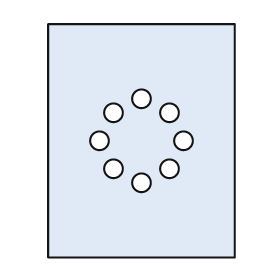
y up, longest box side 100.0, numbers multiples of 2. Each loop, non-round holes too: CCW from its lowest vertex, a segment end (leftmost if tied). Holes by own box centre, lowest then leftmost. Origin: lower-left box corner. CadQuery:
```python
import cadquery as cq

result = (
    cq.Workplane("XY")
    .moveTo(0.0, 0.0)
    .lineTo(80.0, 0.0)
    .lineTo(80.0, 100.0)
    .lineTo(0.0, 100.0)
    .close()
    .moveTo(40.0, 32.0)
    .circle(4.0)
    .moveTo(28.0, 38.0)
    .circle(4.0)
    .moveTo(52.0, 38.0)
    .circle(4.0)
    .moveTo(22.0, 50.0)
    .circle(4.0)
    .moveTo(58.0, 50.0)
    .circle(4.0)
    .moveTo(28.0, 62.0)
    .circle(4.0)
    .moveTo(52.0, 62.0)
    .circle(4.0)
    .moveTo(40.0, 68.0)
    .circle(4.0)
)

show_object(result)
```